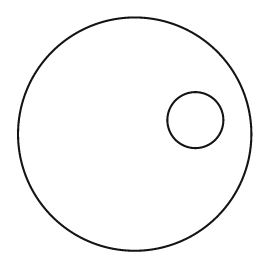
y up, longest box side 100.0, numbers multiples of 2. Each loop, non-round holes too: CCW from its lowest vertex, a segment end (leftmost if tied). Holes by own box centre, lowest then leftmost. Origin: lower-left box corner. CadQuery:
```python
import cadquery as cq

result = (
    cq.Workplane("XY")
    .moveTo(50.0, 50.0)
    .circle(50.0)
    .moveTo(76.0, 56.0)
    .circle(12.0)
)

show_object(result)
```